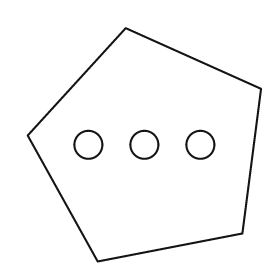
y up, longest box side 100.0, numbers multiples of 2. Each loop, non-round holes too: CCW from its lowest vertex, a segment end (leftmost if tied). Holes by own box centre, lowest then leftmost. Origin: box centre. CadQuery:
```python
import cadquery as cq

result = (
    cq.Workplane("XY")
    .moveTo(-20.0, -50.0)
    .lineTo(42.0, -38.0)
    .lineTo(50.0, 24.0)
    .lineTo(-8.0, 50.0)
    .lineTo(-50.0, 4.0)
    .close()
    .moveTo(-24.0, 0.0)
    .circle(6.0)
    .moveTo(0.0, 0.0)
    .circle(6.0)
    .moveTo(24.0, 0.0)
    .circle(6.0)
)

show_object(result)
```